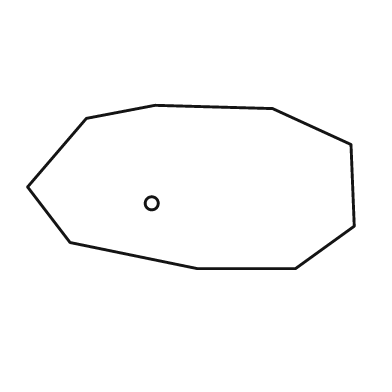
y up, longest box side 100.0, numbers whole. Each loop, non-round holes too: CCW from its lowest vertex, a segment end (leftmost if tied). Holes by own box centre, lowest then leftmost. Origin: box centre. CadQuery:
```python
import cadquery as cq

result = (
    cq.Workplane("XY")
    .moveTo(2.0, -25.0)
    .lineTo(32.0, -25.0)
    .lineTo(50.0, -12.0)
    .lineTo(49.0, 13.0)
    .lineTo(25.0, 24.0)
    .lineTo(-11.0, 25.0)
    .lineTo(-32.0, 21.0)
    .lineTo(-50.0, 0.0)
    .lineTo(-37.0, -17.0)
    .close()
    .moveTo(-12.0, -5.0)
    .circle(2.0)
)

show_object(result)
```